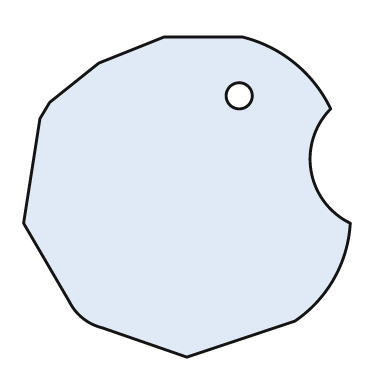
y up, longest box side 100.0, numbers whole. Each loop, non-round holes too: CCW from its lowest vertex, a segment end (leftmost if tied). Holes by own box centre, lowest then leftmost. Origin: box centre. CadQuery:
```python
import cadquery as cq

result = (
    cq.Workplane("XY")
    .moveTo(0.0, -49.0)
    .lineTo(33.0, -38.0)
    .threePointArc((45.0, -25.0), (50.0, -8.0))
    .threePointArc((38.0, 8.0), (44.0, 27.0))
    .threePointArc((33.0, 41.0), (17.0, 49.0))
    .lineTo(-7.0, 49.0)
    .lineTo(-27.0, 41.0)
    .lineTo(-42.0, 29.0)
    .lineTo(-45.0, 24.0)
    .lineTo(-50.0, -8.0)
    .lineTo(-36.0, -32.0)
    .threePointArc((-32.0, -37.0), (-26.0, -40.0))
    .close()
    .moveTo(16.0, 31.0)
    .circle(4.0)
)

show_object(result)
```